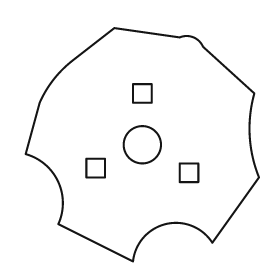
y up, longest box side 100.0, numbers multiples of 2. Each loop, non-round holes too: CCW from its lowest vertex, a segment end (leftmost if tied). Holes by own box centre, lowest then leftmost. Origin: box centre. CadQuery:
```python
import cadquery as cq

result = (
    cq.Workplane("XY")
    .moveTo(-4.0, -50.0)
    .threePointArc((10.0, -34.0), (30.0, -42.0))
    .lineTo(50.0, -14.0)
    .threePointArc((46.0, 4.0), (48.0, 22.0))
    .lineTo(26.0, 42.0)
    .threePointArc((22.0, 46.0), (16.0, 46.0))
    .lineTo(-12.0, 50.0)
    .lineTo(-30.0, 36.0)
    .threePointArc((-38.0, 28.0), (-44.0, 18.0))
    .lineTo(-50.0, -4.0)
    .threePointArc((-36.0, -16.0), (-36.0, -34.0))
    .close()
    .moveTo(16.0, -16.0)
    .lineTo(24.0, -16.0)
    .lineTo(24.0, -8.0)
    .lineTo(16.0, -8.0)
    .close()
    .moveTo(-24.0, -14.0)
    .lineTo(-16.0, -14.0)
    .lineTo(-16.0, -6.0)
    .lineTo(-24.0, -6.0)
    .close()
    .moveTo(0.0, 0.0)
    .circle(8.0)
    .moveTo(-4.0, 18.0)
    .lineTo(4.0, 18.0)
    .lineTo(4.0, 26.0)
    .lineTo(-4.0, 26.0)
    .close()
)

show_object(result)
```